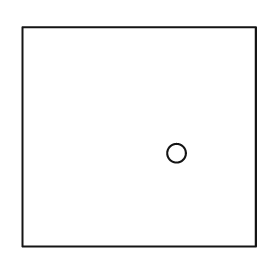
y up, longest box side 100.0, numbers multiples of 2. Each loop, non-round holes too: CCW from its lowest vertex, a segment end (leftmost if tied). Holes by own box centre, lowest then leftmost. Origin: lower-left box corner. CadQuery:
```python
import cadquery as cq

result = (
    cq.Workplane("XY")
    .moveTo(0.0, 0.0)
    .lineTo(100.0, 0.0)
    .lineTo(100.0, 94.0)
    .lineTo(0.0, 94.0)
    .close()
    .moveTo(66.0, 40.0)
    .circle(4.0)
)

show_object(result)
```